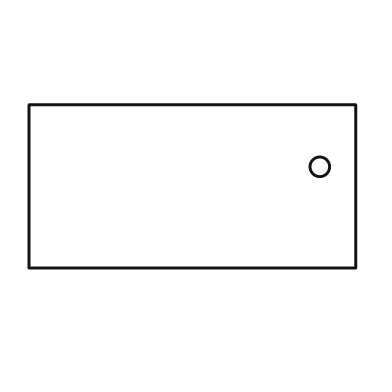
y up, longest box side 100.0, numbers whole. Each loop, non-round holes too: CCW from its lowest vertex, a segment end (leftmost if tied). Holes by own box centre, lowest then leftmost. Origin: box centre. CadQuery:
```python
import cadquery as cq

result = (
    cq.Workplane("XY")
    .moveTo(-50.0, -25.0)
    .lineTo(50.0, -25.0)
    .lineTo(50.0, 25.0)
    .lineTo(-50.0, 25.0)
    .close()
    .moveTo(39.0, 6.0)
    .circle(3.0)
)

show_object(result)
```